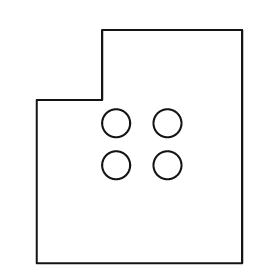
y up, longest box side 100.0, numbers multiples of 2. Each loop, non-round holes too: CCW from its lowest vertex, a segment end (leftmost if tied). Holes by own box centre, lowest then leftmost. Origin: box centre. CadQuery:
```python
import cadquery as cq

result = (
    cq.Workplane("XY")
    .moveTo(-44.0, -50.0)
    .lineTo(44.0, -50.0)
    .lineTo(44.0, 50.0)
    .lineTo(-16.0, 50.0)
    .lineTo(-16.0, 20.0)
    .lineTo(-44.0, 20.0)
    .close()
    .moveTo(-10.0, -8.0)
    .circle(6.0)
    .moveTo(12.0, -8.0)
    .circle(6.0)
    .moveTo(-10.0, 10.0)
    .circle(6.0)
    .moveTo(12.0, 10.0)
    .circle(6.0)
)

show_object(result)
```